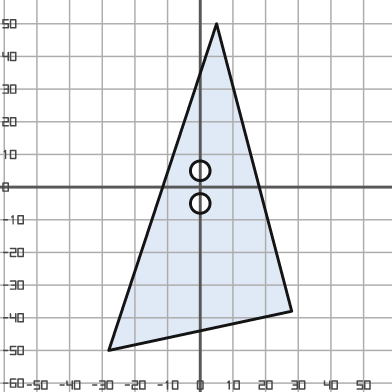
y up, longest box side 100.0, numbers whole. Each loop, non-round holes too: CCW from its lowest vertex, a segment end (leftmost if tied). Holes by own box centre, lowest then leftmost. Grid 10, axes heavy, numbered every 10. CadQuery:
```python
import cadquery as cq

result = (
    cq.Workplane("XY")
    .moveTo(-28.0, -50.0)
    .lineTo(28.0, -38.0)
    .lineTo(5.0, 50.0)
    .close()
    .moveTo(0.0, -5.0)
    .circle(3.0)
    .moveTo(0.0, 5.0)
    .circle(3.0)
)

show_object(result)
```